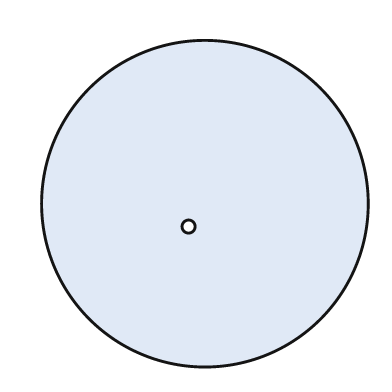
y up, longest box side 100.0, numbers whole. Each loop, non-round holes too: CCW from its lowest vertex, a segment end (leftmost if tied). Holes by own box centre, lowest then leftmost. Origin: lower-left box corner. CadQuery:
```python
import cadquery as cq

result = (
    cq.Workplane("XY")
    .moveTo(50.0, 50.0)
    .circle(50.0)
    .moveTo(45.0, 43.0)
    .circle(2.0)
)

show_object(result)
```